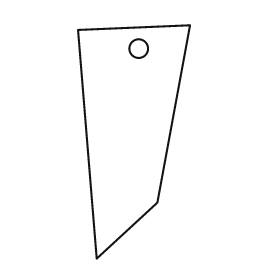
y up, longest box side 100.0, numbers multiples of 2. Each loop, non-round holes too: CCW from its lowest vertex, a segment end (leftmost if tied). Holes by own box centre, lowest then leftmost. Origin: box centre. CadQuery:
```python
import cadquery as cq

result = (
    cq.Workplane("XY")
    .moveTo(-16.0, -50.0)
    .lineTo(10.0, -26.0)
    .lineTo(24.0, 50.0)
    .lineTo(-24.0, 48.0)
    .close()
    .moveTo(2.0, 40.0)
    .circle(4.0)
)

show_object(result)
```